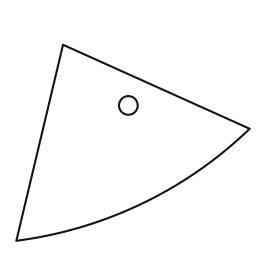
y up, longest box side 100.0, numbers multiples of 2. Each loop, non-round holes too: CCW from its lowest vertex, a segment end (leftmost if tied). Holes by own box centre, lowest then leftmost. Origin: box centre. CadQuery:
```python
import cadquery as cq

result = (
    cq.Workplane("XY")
    .moveTo(-50.0, -42.0)
    .threePointArc((4.0, -26.0), (50.0, 6.0))
    .lineTo(-30.0, 42.0)
    .close()
    .moveTo(-2.0, 16.0)
    .circle(4.0)
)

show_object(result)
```